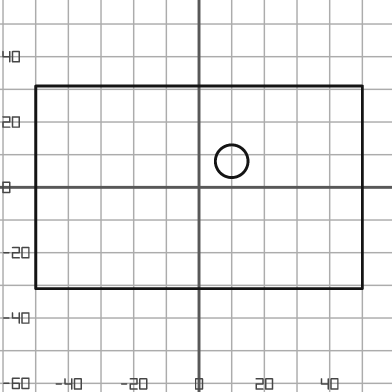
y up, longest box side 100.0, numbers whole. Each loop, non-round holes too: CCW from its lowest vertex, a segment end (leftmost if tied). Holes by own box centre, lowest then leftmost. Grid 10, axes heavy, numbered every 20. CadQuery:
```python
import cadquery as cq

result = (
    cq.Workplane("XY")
    .moveTo(-50.0, -31.0)
    .lineTo(50.0, -31.0)
    .lineTo(50.0, 31.0)
    .lineTo(-50.0, 31.0)
    .close()
    .moveTo(10.0, 8.0)
    .circle(5.0)
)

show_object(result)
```